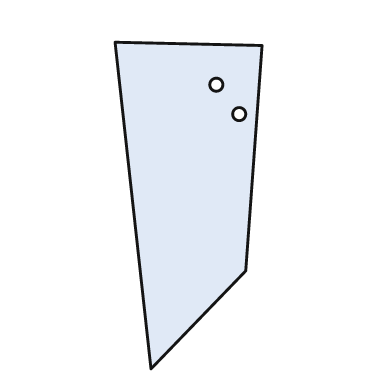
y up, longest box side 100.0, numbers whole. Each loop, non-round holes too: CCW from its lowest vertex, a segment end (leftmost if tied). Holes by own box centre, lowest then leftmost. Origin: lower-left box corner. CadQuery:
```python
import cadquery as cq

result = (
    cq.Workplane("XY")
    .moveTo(11.0, 0.0)
    .lineTo(40.0, 30.0)
    .lineTo(45.0, 99.0)
    .lineTo(0.0, 100.0)
    .close()
    .moveTo(38.0, 78.0)
    .circle(2.0)
    .moveTo(31.0, 87.0)
    .circle(2.0)
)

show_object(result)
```